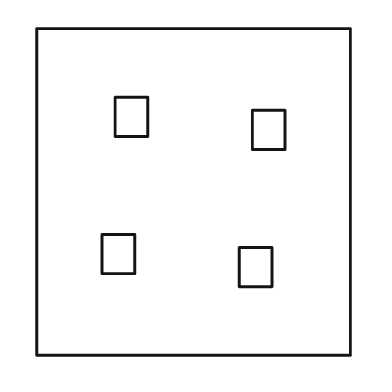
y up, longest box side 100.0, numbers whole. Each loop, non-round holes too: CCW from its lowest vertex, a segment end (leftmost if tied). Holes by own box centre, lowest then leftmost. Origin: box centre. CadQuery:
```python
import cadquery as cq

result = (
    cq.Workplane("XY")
    .moveTo(-48.0, -50.0)
    .lineTo(48.0, -50.0)
    .lineTo(48.0, 50.0)
    .lineTo(-48.0, 50.0)
    .close()
    .moveTo(14.0, -29.0)
    .lineTo(24.0, -29.0)
    .lineTo(24.0, -17.0)
    .lineTo(14.0, -17.0)
    .close()
    .moveTo(-28.0, -25.0)
    .lineTo(-18.0, -25.0)
    .lineTo(-18.0, -13.0)
    .lineTo(-28.0, -13.0)
    .close()
    .moveTo(18.0, 13.0)
    .lineTo(28.0, 13.0)
    .lineTo(28.0, 25.0)
    .lineTo(18.0, 25.0)
    .close()
    .moveTo(-24.0, 17.0)
    .lineTo(-14.0, 17.0)
    .lineTo(-14.0, 29.0)
    .lineTo(-24.0, 29.0)
    .close()
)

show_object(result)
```